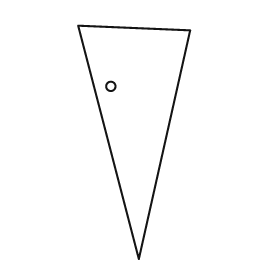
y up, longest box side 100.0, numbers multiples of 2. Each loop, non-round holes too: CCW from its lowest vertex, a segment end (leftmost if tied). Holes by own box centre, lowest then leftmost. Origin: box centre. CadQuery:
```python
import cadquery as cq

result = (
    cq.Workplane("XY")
    .moveTo(2.0, -50.0)
    .lineTo(24.0, 48.0)
    .lineTo(-24.0, 50.0)
    .close()
    .moveTo(-10.0, 24.0)
    .circle(2.0)
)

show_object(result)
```